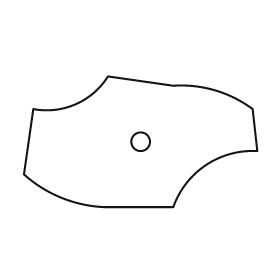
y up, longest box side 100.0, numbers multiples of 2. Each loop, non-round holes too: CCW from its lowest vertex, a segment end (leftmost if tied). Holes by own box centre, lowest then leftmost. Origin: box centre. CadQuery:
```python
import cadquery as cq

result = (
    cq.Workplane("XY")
    .moveTo(-16.0, -28.0)
    .lineTo(14.0, -28.0)
    .threePointArc((28.0, -10.0), (50.0, -4.0))
    .lineTo(48.0, 14.0)
    .threePointArc((32.0, 22.0), (14.0, 24.0))
    .lineTo(-14.0, 28.0)
    .threePointArc((-28.0, 16.0), (-46.0, 14.0))
    .lineTo(-50.0, -14.0)
    .threePointArc((-34.0, -24.0), (-16.0, -28.0))
    .close()
    .moveTo(0.0, 0.0)
    .circle(4.0)
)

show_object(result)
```